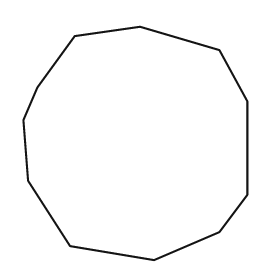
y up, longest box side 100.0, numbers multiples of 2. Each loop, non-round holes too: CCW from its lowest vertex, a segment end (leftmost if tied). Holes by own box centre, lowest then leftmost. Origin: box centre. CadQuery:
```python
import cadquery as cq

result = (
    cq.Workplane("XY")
    .moveTo(8.0, -50.0)
    .lineTo(36.0, -38.0)
    .lineTo(48.0, -22.0)
    .lineTo(48.0, 18.0)
    .lineTo(36.0, 40.0)
    .lineTo(2.0, 50.0)
    .lineTo(-26.0, 46.0)
    .lineTo(-42.0, 24.0)
    .lineTo(-48.0, 10.0)
    .lineTo(-46.0, -16.0)
    .lineTo(-28.0, -44.0)
    .close()
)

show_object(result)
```